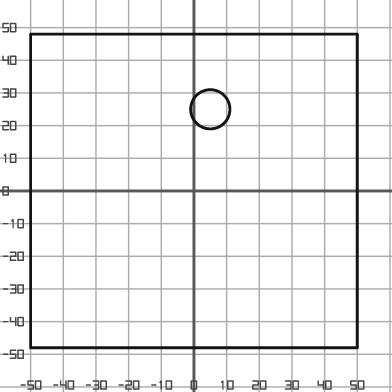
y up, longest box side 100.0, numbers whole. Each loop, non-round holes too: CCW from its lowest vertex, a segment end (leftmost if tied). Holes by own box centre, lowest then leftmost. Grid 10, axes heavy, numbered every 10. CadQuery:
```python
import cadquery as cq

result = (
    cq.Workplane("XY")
    .moveTo(-50.0, -48.0)
    .lineTo(50.0, -48.0)
    .lineTo(50.0, 48.0)
    .lineTo(-50.0, 48.0)
    .close()
    .moveTo(5.0, 25.0)
    .circle(6.0)
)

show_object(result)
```